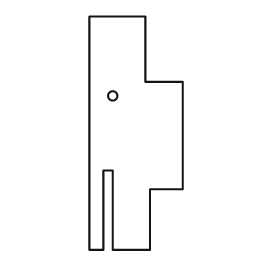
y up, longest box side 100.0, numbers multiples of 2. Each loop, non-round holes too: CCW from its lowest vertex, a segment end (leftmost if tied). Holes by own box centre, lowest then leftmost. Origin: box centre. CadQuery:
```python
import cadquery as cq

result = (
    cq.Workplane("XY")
    .moveTo(-20.0, -50.0)
    .lineTo(-14.0, -50.0)
    .lineTo(-14.0, -16.0)
    .lineTo(-10.0, -16.0)
    .lineTo(-10.0, -50.0)
    .lineTo(6.0, -50.0)
    .lineTo(6.0, -24.0)
    .lineTo(20.0, -24.0)
    .lineTo(20.0, 22.0)
    .lineTo(4.0, 22.0)
    .lineTo(4.0, 50.0)
    .lineTo(-20.0, 50.0)
    .close()
    .moveTo(-10.0, 16.0)
    .circle(2.0)
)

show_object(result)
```